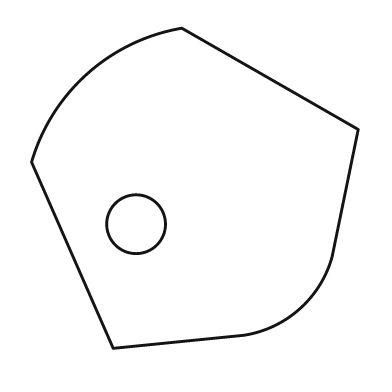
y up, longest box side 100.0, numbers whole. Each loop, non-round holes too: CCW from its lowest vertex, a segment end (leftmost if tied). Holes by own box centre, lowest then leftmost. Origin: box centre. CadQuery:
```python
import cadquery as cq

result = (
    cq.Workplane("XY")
    .moveTo(-25.0, -49.0)
    .lineTo(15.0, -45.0)
    .threePointArc((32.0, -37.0), (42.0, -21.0))
    .lineTo(50.0, 18.0)
    .lineTo(-4.0, 49.0)
    .threePointArc((-33.0, 35.0), (-50.0, 8.0))
    .close()
    .moveTo(-18.0, -11.0)
    .circle(9.0)
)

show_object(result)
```